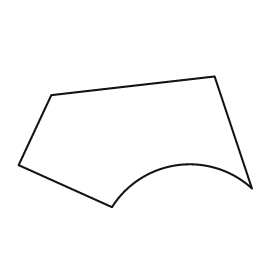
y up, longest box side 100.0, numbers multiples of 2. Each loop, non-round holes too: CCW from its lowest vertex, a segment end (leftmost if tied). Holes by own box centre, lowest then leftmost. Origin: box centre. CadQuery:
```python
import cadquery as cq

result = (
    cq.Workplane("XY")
    .moveTo(-10.0, -28.0)
    .threePointArc((18.0, -10.0), (50.0, -20.0))
    .lineTo(34.0, 28.0)
    .lineTo(-36.0, 20.0)
    .lineTo(-50.0, -10.0)
    .close()
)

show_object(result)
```